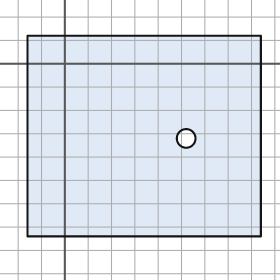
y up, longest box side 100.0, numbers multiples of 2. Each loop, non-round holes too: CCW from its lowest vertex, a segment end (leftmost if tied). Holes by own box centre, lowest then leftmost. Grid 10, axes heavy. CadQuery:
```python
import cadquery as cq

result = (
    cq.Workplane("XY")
    .moveTo(-16.0, -74.0)
    .lineTo(84.0, -74.0)
    .lineTo(84.0, 12.0)
    .lineTo(-16.0, 12.0)
    .close()
    .moveTo(52.0, -32.0)
    .circle(4.0)
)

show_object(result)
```